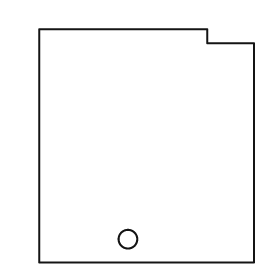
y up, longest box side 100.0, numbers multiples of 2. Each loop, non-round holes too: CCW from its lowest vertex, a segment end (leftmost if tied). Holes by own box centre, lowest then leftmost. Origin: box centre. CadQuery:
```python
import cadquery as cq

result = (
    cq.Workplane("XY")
    .moveTo(-46.0, -50.0)
    .lineTo(46.0, -50.0)
    .lineTo(46.0, 44.0)
    .lineTo(26.0, 44.0)
    .lineTo(26.0, 50.0)
    .lineTo(-46.0, 50.0)
    .close()
    .moveTo(-8.0, -40.0)
    .circle(4.0)
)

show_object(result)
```